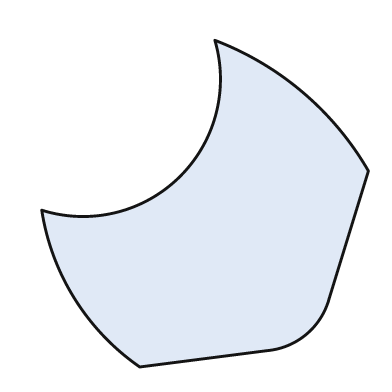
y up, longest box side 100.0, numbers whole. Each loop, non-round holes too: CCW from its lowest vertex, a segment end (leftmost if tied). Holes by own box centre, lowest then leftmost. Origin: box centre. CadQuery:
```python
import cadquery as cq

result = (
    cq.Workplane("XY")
    .moveTo(-20.0, -50.0)
    .lineTo(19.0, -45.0)
    .threePointArc((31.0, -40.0), (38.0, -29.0))
    .lineTo(50.0, 10.0)
    .threePointArc((30.0, 34.0), (3.0, 50.0))
    .threePointArc((-8.0, 8.0), (-50.0, -2.0))
    .threePointArc((-40.0, -29.0), (-20.0, -50.0))
    .close()
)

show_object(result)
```